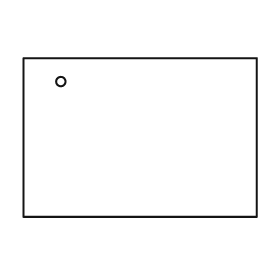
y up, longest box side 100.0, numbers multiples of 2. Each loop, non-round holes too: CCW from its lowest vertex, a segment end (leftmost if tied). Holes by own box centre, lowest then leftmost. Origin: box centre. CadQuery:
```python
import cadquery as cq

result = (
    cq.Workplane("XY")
    .moveTo(-50.0, -34.0)
    .lineTo(50.0, -34.0)
    .lineTo(50.0, 34.0)
    .lineTo(-50.0, 34.0)
    .close()
    .moveTo(-34.0, 24.0)
    .circle(2.0)
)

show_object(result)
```